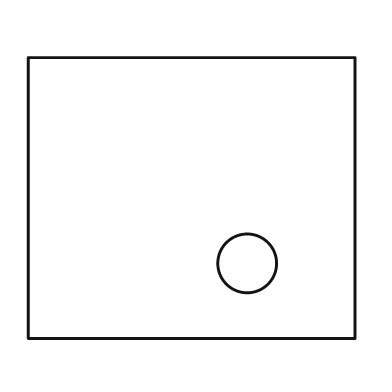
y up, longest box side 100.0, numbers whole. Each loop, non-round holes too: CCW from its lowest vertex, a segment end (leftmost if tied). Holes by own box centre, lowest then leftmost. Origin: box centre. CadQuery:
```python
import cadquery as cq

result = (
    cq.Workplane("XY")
    .moveTo(-50.0, -43.0)
    .lineTo(50.0, -43.0)
    .lineTo(50.0, 43.0)
    .lineTo(-50.0, 43.0)
    .close()
    .moveTo(17.0, -20.0)
    .circle(9.0)
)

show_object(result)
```